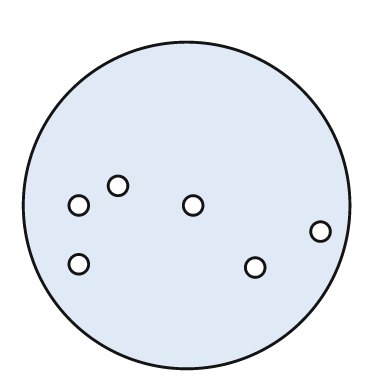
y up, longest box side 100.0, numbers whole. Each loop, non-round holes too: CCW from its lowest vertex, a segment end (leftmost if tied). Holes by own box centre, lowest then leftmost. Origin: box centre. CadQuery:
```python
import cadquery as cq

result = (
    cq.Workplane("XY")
    .moveTo(0.0, 0.0)
    .circle(50.0)
    .moveTo(21.0, -19.0)
    .circle(3.0)
    .moveTo(-33.0, -18.0)
    .circle(3.0)
    .moveTo(41.0, -8.0)
    .circle(3.0)
    .moveTo(-33.0, 0.0)
    .circle(3.0)
    .moveTo(2.0, 0.0)
    .circle(3.0)
    .moveTo(-21.0, 6.0)
    .circle(3.0)
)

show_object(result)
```